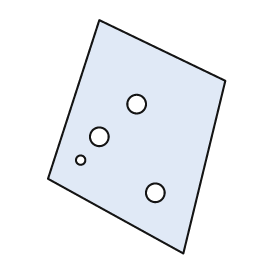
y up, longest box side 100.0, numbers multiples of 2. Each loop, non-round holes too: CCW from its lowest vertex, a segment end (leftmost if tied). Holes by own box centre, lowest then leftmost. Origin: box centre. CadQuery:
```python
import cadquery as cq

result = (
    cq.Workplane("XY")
    .moveTo(20.0, -50.0)
    .lineTo(38.0, 24.0)
    .lineTo(-16.0, 50.0)
    .lineTo(-38.0, -18.0)
    .close()
    .moveTo(8.0, -24.0)
    .circle(4.0)
    .moveTo(-24.0, -10.0)
    .circle(2.0)
    .moveTo(-16.0, 0.0)
    .circle(4.0)
    .moveTo(0.0, 14.0)
    .circle(4.0)
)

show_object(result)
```